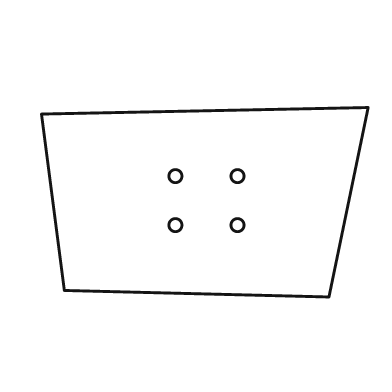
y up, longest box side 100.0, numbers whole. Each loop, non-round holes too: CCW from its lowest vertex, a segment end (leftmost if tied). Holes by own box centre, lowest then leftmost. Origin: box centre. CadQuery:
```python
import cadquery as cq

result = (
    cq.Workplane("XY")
    .moveTo(38.0, -29.0)
    .lineTo(50.0, 29.0)
    .lineTo(-50.0, 27.0)
    .lineTo(-43.0, -27.0)
    .close()
    .moveTo(-9.0, -7.0)
    .circle(2.0)
    .moveTo(10.0, -7.0)
    .circle(2.0)
    .moveTo(-9.0, 8.0)
    .circle(2.0)
    .moveTo(10.0, 8.0)
    .circle(2.0)
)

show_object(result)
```